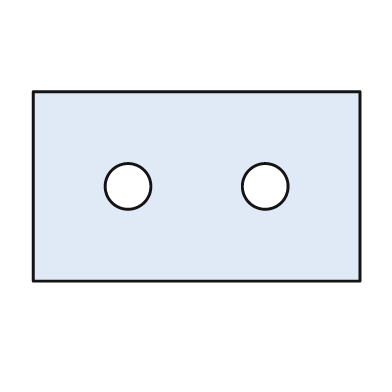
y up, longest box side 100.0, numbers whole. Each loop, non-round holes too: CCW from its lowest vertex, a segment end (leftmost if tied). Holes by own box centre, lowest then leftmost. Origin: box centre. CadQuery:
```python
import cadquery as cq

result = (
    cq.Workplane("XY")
    .moveTo(-50.0, -29.0)
    .lineTo(50.0, -29.0)
    .lineTo(50.0, 29.0)
    .lineTo(-50.0, 29.0)
    .close()
    .moveTo(-21.0, 0.0)
    .circle(7.0)
    .moveTo(21.0, 0.0)
    .circle(7.0)
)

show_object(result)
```